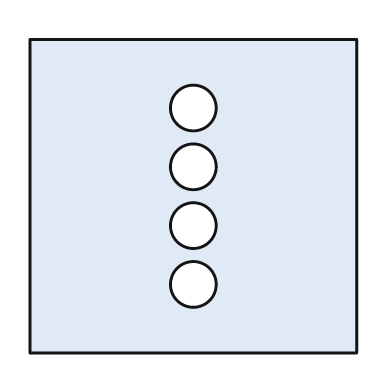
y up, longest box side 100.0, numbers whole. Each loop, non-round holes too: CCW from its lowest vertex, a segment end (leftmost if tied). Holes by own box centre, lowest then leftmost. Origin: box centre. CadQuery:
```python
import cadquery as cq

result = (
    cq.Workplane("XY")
    .moveTo(-50.0, -48.0)
    .lineTo(50.0, -48.0)
    .lineTo(50.0, 48.0)
    .lineTo(-50.0, 48.0)
    .close()
    .moveTo(0.0, -27.0)
    .circle(7.0)
    .moveTo(0.0, -9.0)
    .circle(7.0)
    .moveTo(0.0, 9.0)
    .circle(7.0)
    .moveTo(0.0, 27.0)
    .circle(7.0)
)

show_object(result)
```